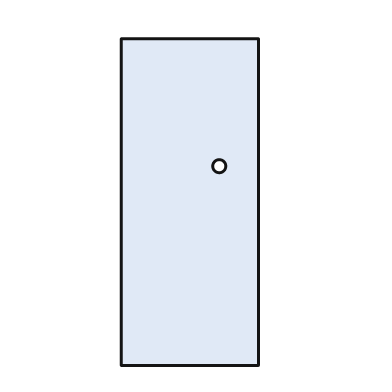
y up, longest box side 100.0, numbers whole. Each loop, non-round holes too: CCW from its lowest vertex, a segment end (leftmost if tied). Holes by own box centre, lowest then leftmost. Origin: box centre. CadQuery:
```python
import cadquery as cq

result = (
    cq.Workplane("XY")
    .moveTo(-21.0, -50.0)
    .lineTo(21.0, -50.0)
    .lineTo(21.0, 50.0)
    .lineTo(-21.0, 50.0)
    .close()
    .moveTo(9.0, 11.0)
    .circle(2.0)
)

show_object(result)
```